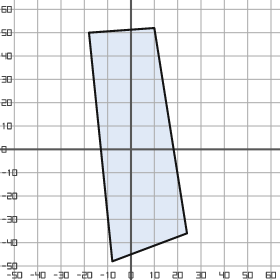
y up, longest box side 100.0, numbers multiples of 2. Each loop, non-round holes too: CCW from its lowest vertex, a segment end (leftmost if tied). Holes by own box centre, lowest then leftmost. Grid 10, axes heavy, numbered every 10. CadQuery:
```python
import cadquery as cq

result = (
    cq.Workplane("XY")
    .moveTo(-8.0, -48.0)
    .lineTo(24.0, -36.0)
    .lineTo(10.0, 52.0)
    .lineTo(-18.0, 50.0)
    .close()
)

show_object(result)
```